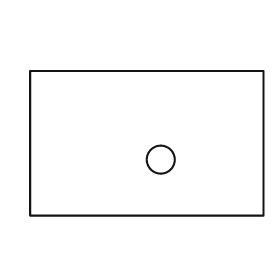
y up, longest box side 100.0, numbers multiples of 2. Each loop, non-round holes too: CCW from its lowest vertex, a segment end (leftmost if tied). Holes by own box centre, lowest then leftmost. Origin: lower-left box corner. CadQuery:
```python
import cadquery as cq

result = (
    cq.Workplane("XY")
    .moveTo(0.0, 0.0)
    .lineTo(100.0, 0.0)
    .lineTo(100.0, 62.0)
    .lineTo(0.0, 62.0)
    .close()
    .moveTo(56.0, 24.0)
    .circle(6.0)
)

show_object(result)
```